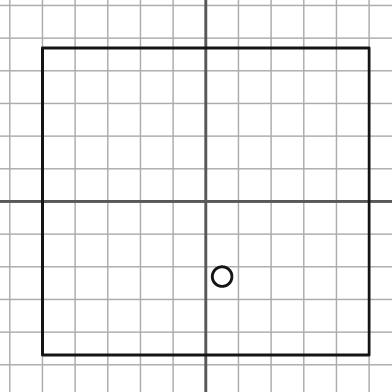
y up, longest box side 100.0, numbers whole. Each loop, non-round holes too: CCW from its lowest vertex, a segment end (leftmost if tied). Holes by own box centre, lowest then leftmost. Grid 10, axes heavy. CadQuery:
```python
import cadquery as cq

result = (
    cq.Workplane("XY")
    .moveTo(-50.0, -47.0)
    .lineTo(50.0, -47.0)
    .lineTo(50.0, 47.0)
    .lineTo(-50.0, 47.0)
    .close()
    .moveTo(5.0, -23.0)
    .circle(3.0)
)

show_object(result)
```